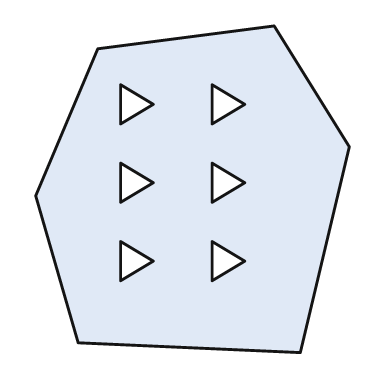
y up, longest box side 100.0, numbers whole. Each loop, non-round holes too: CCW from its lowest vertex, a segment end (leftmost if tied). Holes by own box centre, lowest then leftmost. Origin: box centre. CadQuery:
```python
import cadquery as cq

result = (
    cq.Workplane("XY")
    .moveTo(33.0, -50.0)
    .lineTo(48.0, 13.0)
    .lineTo(25.0, 50.0)
    .lineTo(-29.0, 43.0)
    .lineTo(-48.0, -2.0)
    .lineTo(-35.0, -47.0)
    .close()
    .moveTo(-22.0, -28.0)
    .lineTo(-12.0, -22.0)
    .lineTo(-22.0, -16.0)
    .close()
    .moveTo(6.0, -28.0)
    .lineTo(16.0, -22.0)
    .lineTo(6.0, -16.0)
    .close()
    .moveTo(-22.0, -4.0)
    .lineTo(-12.0, 2.0)
    .lineTo(-22.0, 8.0)
    .close()
    .moveTo(6.0, -4.0)
    .lineTo(16.0, 2.0)
    .lineTo(6.0, 8.0)
    .close()
    .moveTo(-22.0, 20.0)
    .lineTo(-12.0, 26.0)
    .lineTo(-22.0, 32.0)
    .close()
    .moveTo(6.0, 20.0)
    .lineTo(16.0, 26.0)
    .lineTo(6.0, 32.0)
    .close()
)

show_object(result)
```